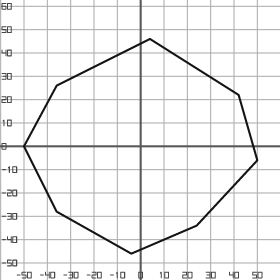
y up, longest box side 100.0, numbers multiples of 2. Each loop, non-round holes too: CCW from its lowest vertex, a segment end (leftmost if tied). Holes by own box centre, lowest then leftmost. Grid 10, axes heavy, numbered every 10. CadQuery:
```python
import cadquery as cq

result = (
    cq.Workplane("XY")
    .moveTo(-4.0, -46.0)
    .lineTo(24.0, -34.0)
    .lineTo(50.0, -6.0)
    .lineTo(42.0, 22.0)
    .lineTo(4.0, 46.0)
    .lineTo(-36.0, 26.0)
    .lineTo(-50.0, 0.0)
    .lineTo(-36.0, -28.0)
    .close()
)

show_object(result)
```